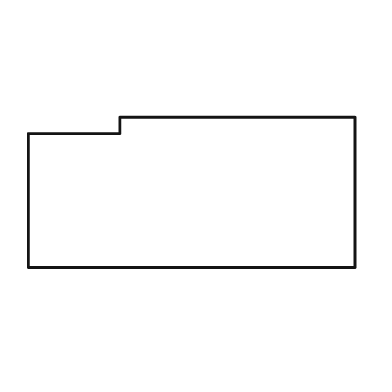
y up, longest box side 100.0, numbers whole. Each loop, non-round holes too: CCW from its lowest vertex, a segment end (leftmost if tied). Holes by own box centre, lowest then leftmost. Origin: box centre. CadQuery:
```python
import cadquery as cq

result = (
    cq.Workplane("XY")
    .moveTo(-50.0, -23.0)
    .lineTo(50.0, -23.0)
    .lineTo(50.0, 23.0)
    .lineTo(-22.0, 23.0)
    .lineTo(-22.0, 18.0)
    .lineTo(-50.0, 18.0)
    .close()
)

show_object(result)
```